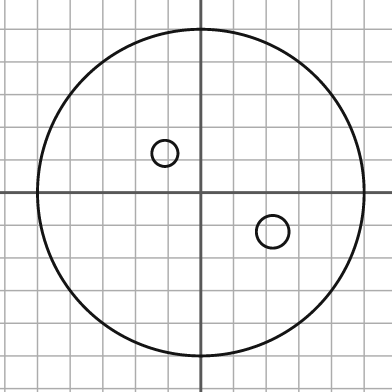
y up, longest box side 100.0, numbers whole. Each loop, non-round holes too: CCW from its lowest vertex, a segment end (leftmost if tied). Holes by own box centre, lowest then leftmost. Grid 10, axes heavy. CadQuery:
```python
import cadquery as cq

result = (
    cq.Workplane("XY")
    .moveTo(0.0, 0.0)
    .circle(50.0)
    .moveTo(22.0, -12.0)
    .circle(5.0)
    .moveTo(-11.0, 12.0)
    .circle(4.0)
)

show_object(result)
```